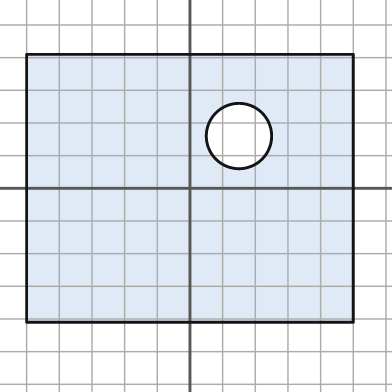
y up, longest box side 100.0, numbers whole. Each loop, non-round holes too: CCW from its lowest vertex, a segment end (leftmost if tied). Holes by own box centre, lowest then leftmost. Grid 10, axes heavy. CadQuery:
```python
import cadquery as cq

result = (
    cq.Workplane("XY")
    .moveTo(-50.0, -41.0)
    .lineTo(50.0, -41.0)
    .lineTo(50.0, 41.0)
    .lineTo(-50.0, 41.0)
    .close()
    .moveTo(15.0, 16.0)
    .circle(10.0)
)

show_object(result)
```